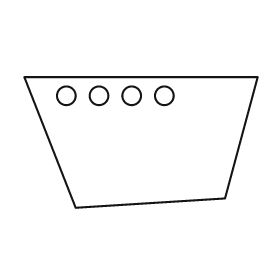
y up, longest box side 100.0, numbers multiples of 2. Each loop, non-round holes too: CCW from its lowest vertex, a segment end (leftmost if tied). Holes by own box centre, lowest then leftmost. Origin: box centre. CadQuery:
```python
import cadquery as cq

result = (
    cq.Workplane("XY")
    .moveTo(-28.0, -28.0)
    .lineTo(36.0, -24.0)
    .lineTo(50.0, 28.0)
    .lineTo(-50.0, 28.0)
    .close()
    .moveTo(-32.0, 20.0)
    .circle(4.0)
    .moveTo(-18.0, 20.0)
    .circle(4.0)
    .moveTo(-4.0, 20.0)
    .circle(4.0)
    .moveTo(10.0, 20.0)
    .circle(4.0)
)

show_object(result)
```